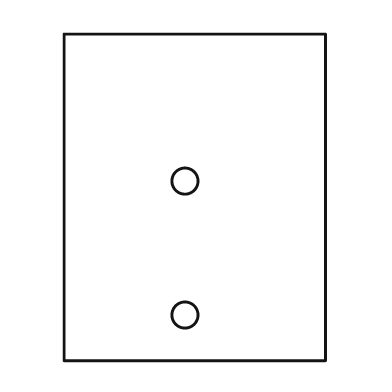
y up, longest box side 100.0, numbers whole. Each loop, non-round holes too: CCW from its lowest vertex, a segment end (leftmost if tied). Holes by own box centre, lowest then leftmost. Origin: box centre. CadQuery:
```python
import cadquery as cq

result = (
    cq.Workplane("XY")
    .moveTo(-40.0, -50.0)
    .lineTo(40.0, -50.0)
    .lineTo(40.0, 50.0)
    .lineTo(-40.0, 50.0)
    .close()
    .moveTo(-3.0, -36.0)
    .circle(4.0)
    .moveTo(-3.0, 5.0)
    .circle(4.0)
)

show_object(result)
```